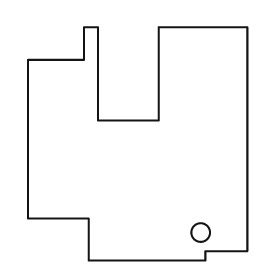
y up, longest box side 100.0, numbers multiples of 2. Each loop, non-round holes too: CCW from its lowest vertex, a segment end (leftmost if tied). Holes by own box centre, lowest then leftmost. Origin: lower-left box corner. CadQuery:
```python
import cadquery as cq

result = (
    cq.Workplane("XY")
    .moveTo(26.0, 0.0)
    .lineTo(76.0, 0.0)
    .lineTo(76.0, 4.0)
    .lineTo(94.0, 4.0)
    .lineTo(94.0, 100.0)
    .lineTo(56.0, 100.0)
    .lineTo(56.0, 60.0)
    .lineTo(30.0, 60.0)
    .lineTo(30.0, 100.0)
    .lineTo(24.0, 100.0)
    .lineTo(24.0, 86.0)
    .lineTo(0.0, 86.0)
    .lineTo(0.0, 18.0)
    .lineTo(26.0, 18.0)
    .close()
    .moveTo(74.0, 12.0)
    .circle(4.0)
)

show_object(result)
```